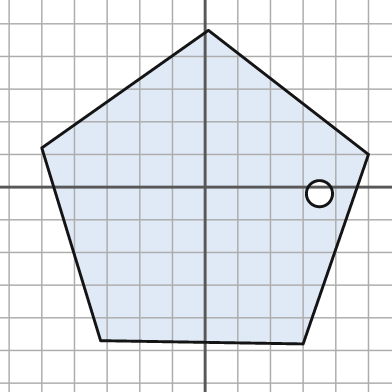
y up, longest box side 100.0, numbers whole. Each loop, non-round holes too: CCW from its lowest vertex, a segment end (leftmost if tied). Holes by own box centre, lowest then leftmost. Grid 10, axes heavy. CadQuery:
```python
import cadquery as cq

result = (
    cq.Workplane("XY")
    .moveTo(30.0, -48.0)
    .lineTo(50.0, 10.0)
    .lineTo(1.0, 48.0)
    .lineTo(-50.0, 12.0)
    .lineTo(-32.0, -47.0)
    .close()
    .moveTo(35.0, -2.0)
    .circle(4.0)
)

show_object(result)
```